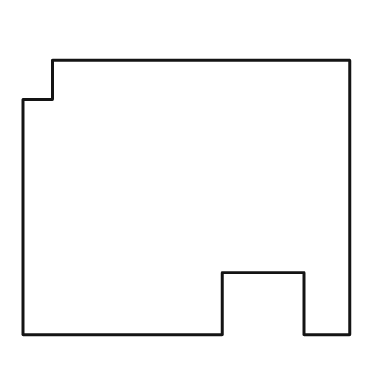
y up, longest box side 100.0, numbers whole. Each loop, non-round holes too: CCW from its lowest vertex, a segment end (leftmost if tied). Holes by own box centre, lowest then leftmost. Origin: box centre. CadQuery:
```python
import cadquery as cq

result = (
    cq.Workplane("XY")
    .moveTo(-50.0, -42.0)
    .lineTo(11.0, -42.0)
    .lineTo(11.0, -23.0)
    .lineTo(36.0, -23.0)
    .lineTo(36.0, -42.0)
    .lineTo(50.0, -42.0)
    .lineTo(50.0, 42.0)
    .lineTo(-41.0, 42.0)
    .lineTo(-41.0, 30.0)
    .lineTo(-50.0, 30.0)
    .close()
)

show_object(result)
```